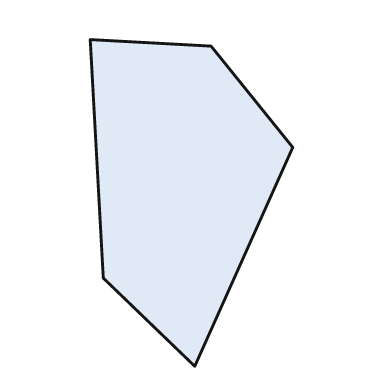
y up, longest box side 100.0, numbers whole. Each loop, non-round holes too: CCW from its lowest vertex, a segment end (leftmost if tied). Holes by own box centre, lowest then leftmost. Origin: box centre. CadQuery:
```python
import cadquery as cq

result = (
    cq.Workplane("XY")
    .moveTo(1.0, -50.0)
    .lineTo(31.0, 17.0)
    .lineTo(6.0, 48.0)
    .lineTo(-31.0, 50.0)
    .lineTo(-27.0, -23.0)
    .close()
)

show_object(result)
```